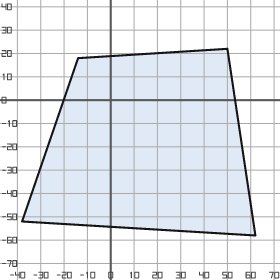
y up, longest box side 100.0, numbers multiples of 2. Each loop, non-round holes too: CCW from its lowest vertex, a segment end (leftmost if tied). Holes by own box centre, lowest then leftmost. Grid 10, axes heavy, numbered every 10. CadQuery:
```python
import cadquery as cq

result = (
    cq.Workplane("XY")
    .moveTo(62.0, -58.0)
    .lineTo(50.0, 22.0)
    .lineTo(-14.0, 18.0)
    .lineTo(-38.0, -52.0)
    .close()
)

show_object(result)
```